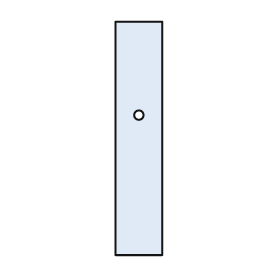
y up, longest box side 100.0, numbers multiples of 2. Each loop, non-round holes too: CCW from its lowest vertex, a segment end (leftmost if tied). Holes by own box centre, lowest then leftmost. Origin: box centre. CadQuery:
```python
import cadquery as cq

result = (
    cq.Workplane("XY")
    .moveTo(-10.0, -50.0)
    .lineTo(10.0, -50.0)
    .lineTo(10.0, 50.0)
    .lineTo(-10.0, 50.0)
    .close()
    .moveTo(0.0, 10.0)
    .circle(2.0)
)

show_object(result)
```